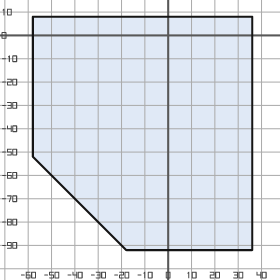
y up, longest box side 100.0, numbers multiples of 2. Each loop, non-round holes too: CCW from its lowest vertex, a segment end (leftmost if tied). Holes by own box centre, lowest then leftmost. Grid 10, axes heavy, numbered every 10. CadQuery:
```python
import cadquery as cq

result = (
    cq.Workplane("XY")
    .moveTo(-18.0, -92.0)
    .lineTo(36.0, -92.0)
    .lineTo(36.0, 8.0)
    .lineTo(-58.0, 8.0)
    .lineTo(-58.0, -52.0)
    .close()
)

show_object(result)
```